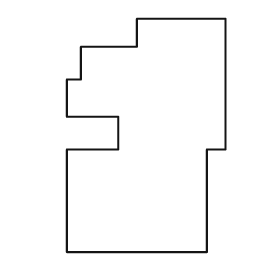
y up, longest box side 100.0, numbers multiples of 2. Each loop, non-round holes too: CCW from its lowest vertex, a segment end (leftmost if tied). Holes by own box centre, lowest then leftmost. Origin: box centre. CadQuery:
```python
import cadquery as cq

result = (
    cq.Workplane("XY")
    .moveTo(-34.0, -50.0)
    .lineTo(26.0, -50.0)
    .lineTo(26.0, -6.0)
    .lineTo(34.0, -6.0)
    .lineTo(34.0, 50.0)
    .lineTo(-4.0, 50.0)
    .lineTo(-4.0, 38.0)
    .lineTo(-28.0, 38.0)
    .lineTo(-28.0, 24.0)
    .lineTo(-34.0, 24.0)
    .lineTo(-34.0, 8.0)
    .lineTo(-12.0, 8.0)
    .lineTo(-12.0, -6.0)
    .lineTo(-34.0, -6.0)
    .close()
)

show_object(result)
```